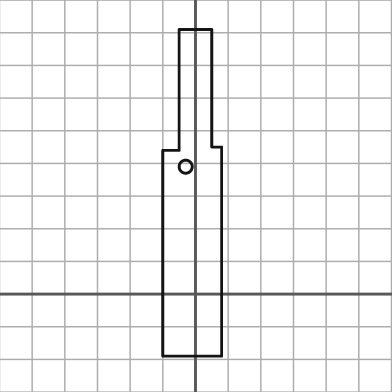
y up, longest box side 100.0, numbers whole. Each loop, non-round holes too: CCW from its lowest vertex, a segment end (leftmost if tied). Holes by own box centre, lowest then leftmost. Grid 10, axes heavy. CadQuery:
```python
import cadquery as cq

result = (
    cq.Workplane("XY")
    .moveTo(-10.0, -19.0)
    .lineTo(8.0, -19.0)
    .lineTo(8.0, 45.0)
    .lineTo(5.0, 45.0)
    .lineTo(5.0, 81.0)
    .lineTo(-5.0, 81.0)
    .lineTo(-5.0, 44.0)
    .lineTo(-10.0, 44.0)
    .close()
    .moveTo(-3.0, 39.0)
    .circle(2.0)
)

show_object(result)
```